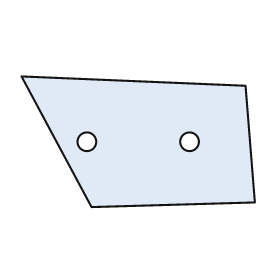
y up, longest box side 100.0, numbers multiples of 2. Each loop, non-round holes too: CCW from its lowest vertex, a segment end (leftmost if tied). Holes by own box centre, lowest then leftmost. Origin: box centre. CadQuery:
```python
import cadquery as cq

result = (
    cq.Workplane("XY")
    .moveTo(-20.0, -28.0)
    .lineTo(50.0, -26.0)
    .lineTo(46.0, 24.0)
    .lineTo(-50.0, 28.0)
    .close()
    .moveTo(-22.0, 0.0)
    .circle(4.0)
    .moveTo(22.0, 0.0)
    .circle(4.0)
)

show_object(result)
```